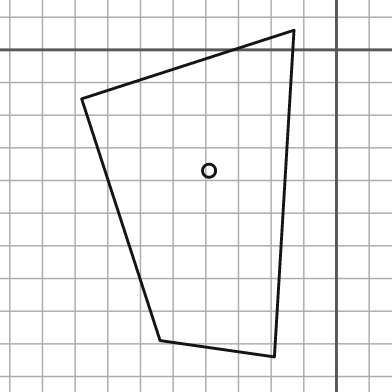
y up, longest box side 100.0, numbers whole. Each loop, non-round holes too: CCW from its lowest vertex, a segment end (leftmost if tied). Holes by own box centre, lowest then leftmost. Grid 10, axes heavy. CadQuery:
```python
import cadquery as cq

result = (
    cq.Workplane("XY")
    .moveTo(-19.0, -94.0)
    .lineTo(-13.0, 6.0)
    .lineTo(-78.0, -15.0)
    .lineTo(-54.0, -89.0)
    .close()
    .moveTo(-39.0, -37.0)
    .circle(2.0)
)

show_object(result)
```